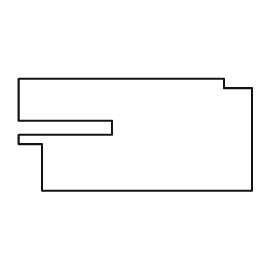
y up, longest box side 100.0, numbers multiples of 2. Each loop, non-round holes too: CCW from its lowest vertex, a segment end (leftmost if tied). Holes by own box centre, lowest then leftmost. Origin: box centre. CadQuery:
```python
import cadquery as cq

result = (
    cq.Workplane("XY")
    .moveTo(-40.0, -24.0)
    .lineTo(50.0, -24.0)
    .lineTo(50.0, 20.0)
    .lineTo(38.0, 20.0)
    .lineTo(38.0, 24.0)
    .lineTo(-50.0, 24.0)
    .lineTo(-50.0, 6.0)
    .lineTo(-10.0, 6.0)
    .lineTo(-10.0, 0.0)
    .lineTo(-50.0, 0.0)
    .lineTo(-50.0, -4.0)
    .lineTo(-40.0, -4.0)
    .close()
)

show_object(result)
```